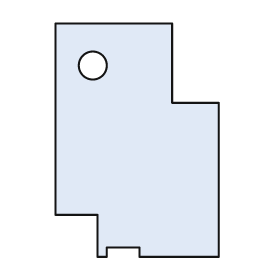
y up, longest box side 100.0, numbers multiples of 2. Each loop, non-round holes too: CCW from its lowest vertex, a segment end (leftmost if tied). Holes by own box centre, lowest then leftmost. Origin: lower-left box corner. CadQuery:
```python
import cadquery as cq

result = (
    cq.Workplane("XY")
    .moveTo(18.0, 0.0)
    .lineTo(22.0, 0.0)
    .lineTo(22.0, 4.0)
    .lineTo(36.0, 4.0)
    .lineTo(36.0, 0.0)
    .lineTo(70.0, 0.0)
    .lineTo(70.0, 66.0)
    .lineTo(50.0, 66.0)
    .lineTo(50.0, 100.0)
    .lineTo(0.0, 100.0)
    .lineTo(0.0, 18.0)
    .lineTo(18.0, 18.0)
    .close()
    .moveTo(16.0, 82.0)
    .circle(6.0)
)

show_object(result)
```